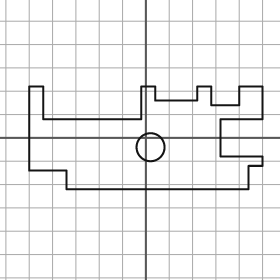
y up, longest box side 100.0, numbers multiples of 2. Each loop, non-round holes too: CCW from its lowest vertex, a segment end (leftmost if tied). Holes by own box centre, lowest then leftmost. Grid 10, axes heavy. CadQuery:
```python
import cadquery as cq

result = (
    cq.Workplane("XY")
    .moveTo(-34.0, -22.0)
    .lineTo(44.0, -22.0)
    .lineTo(44.0, -12.0)
    .lineTo(50.0, -12.0)
    .lineTo(50.0, -8.0)
    .lineTo(32.0, -8.0)
    .lineTo(32.0, 8.0)
    .lineTo(50.0, 8.0)
    .lineTo(50.0, 22.0)
    .lineTo(40.0, 22.0)
    .lineTo(40.0, 14.0)
    .lineTo(28.0, 14.0)
    .lineTo(28.0, 22.0)
    .lineTo(22.0, 22.0)
    .lineTo(22.0, 16.0)
    .lineTo(4.0, 16.0)
    .lineTo(4.0, 22.0)
    .lineTo(-2.0, 22.0)
    .lineTo(-2.0, 8.0)
    .lineTo(-44.0, 8.0)
    .lineTo(-44.0, 22.0)
    .lineTo(-50.0, 22.0)
    .lineTo(-50.0, -14.0)
    .lineTo(-34.0, -14.0)
    .close()
    .moveTo(2.0, -4.0)
    .circle(6.0)
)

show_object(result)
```